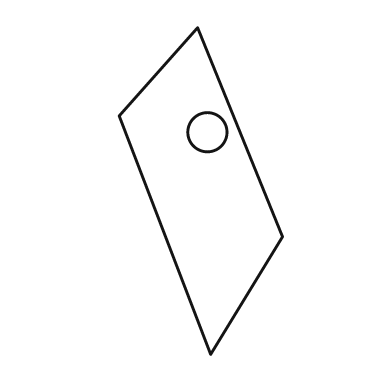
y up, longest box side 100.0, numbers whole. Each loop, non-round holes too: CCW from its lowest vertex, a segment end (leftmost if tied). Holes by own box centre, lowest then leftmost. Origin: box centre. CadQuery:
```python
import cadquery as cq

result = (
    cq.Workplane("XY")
    .moveTo(3.0, -50.0)
    .lineTo(25.0, -14.0)
    .lineTo(-1.0, 50.0)
    .lineTo(-25.0, 23.0)
    .close()
    .moveTo(2.0, 18.0)
    .circle(6.0)
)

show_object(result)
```